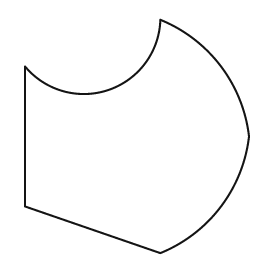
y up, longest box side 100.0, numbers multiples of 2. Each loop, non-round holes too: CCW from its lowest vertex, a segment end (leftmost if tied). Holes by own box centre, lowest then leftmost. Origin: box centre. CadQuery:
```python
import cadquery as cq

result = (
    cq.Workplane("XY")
    .moveTo(10.0, -50.0)
    .threePointArc((36.0, -30.0), (48.0, 0.0))
    .threePointArc((36.0, 30.0), (10.0, 50.0))
    .threePointArc((-12.0, 20.0), (-48.0, 30.0))
    .lineTo(-48.0, -30.0)
    .close()
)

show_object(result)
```